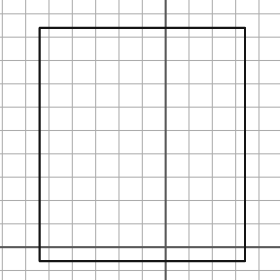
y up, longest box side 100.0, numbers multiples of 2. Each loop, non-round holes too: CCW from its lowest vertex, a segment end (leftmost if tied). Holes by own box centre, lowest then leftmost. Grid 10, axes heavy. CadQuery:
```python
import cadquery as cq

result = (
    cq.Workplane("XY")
    .moveTo(-54.0, -6.0)
    .lineTo(34.0, -6.0)
    .lineTo(34.0, 94.0)
    .lineTo(-54.0, 94.0)
    .close()
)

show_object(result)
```